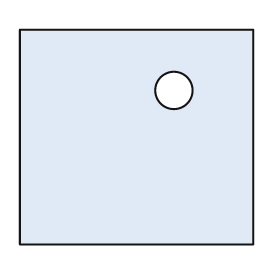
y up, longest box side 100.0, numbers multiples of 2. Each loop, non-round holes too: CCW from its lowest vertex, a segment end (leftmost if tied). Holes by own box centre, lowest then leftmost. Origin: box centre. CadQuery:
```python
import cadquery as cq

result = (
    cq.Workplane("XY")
    .moveTo(-50.0, -46.0)
    .lineTo(50.0, -46.0)
    .lineTo(50.0, 46.0)
    .lineTo(-50.0, 46.0)
    .close()
    .moveTo(16.0, 20.0)
    .circle(8.0)
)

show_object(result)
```